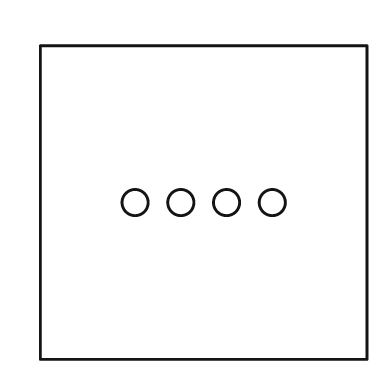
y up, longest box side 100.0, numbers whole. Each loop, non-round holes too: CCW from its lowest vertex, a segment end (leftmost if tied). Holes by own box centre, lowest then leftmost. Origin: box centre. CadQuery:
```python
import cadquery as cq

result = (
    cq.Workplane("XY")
    .moveTo(-50.0, -48.0)
    .lineTo(50.0, -48.0)
    .lineTo(50.0, 48.0)
    .lineTo(-50.0, 48.0)
    .close()
    .moveTo(-21.0, 0.0)
    .circle(4.0)
    .moveTo(-7.0, 0.0)
    .circle(4.0)
    .moveTo(7.0, 0.0)
    .circle(4.0)
    .moveTo(21.0, 0.0)
    .circle(4.0)
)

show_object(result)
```